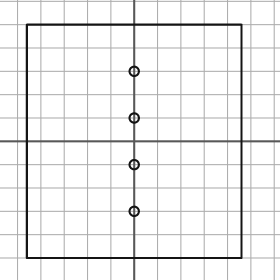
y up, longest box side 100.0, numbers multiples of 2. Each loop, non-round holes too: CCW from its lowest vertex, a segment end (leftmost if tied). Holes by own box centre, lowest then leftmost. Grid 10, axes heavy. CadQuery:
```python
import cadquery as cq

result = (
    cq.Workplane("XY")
    .moveTo(-46.0, -50.0)
    .lineTo(46.0, -50.0)
    .lineTo(46.0, 50.0)
    .lineTo(-46.0, 50.0)
    .close()
    .moveTo(0.0, -30.0)
    .circle(2.0)
    .moveTo(0.0, -10.0)
    .circle(2.0)
    .moveTo(0.0, 10.0)
    .circle(2.0)
    .moveTo(0.0, 30.0)
    .circle(2.0)
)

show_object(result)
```